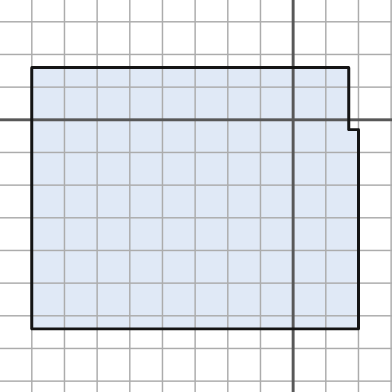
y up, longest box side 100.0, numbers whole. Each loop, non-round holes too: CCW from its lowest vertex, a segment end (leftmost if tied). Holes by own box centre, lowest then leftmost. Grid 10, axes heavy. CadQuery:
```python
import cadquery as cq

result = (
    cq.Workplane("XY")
    .moveTo(-80.0, -64.0)
    .lineTo(20.0, -64.0)
    .lineTo(20.0, -3.0)
    .lineTo(17.0, -3.0)
    .lineTo(17.0, 16.0)
    .lineTo(-80.0, 16.0)
    .close()
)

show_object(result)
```